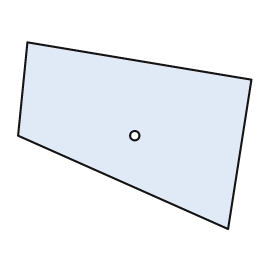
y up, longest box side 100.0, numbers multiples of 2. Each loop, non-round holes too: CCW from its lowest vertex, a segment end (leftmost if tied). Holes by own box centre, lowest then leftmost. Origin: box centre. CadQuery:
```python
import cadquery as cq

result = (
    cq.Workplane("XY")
    .moveTo(40.0, -40.0)
    .lineTo(50.0, 24.0)
    .lineTo(-46.0, 40.0)
    .lineTo(-50.0, 0.0)
    .close()
    .moveTo(0.0, 0.0)
    .circle(2.0)
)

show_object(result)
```